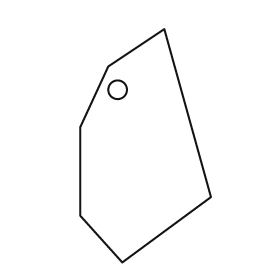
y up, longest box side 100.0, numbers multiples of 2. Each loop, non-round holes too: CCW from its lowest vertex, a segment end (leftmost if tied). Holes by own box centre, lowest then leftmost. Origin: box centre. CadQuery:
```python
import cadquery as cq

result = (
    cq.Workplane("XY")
    .moveTo(-10.0, -50.0)
    .lineTo(28.0, -22.0)
    .lineTo(8.0, 50.0)
    .lineTo(-16.0, 34.0)
    .lineTo(-28.0, 8.0)
    .lineTo(-28.0, -30.0)
    .close()
    .moveTo(-12.0, 24.0)
    .circle(4.0)
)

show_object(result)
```